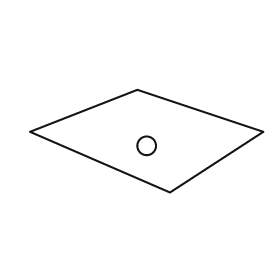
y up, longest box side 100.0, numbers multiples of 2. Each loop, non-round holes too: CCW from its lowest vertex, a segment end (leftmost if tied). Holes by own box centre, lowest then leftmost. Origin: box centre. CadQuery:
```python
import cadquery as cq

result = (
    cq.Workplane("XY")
    .moveTo(10.0, -22.0)
    .lineTo(50.0, 4.0)
    .lineTo(-4.0, 22.0)
    .lineTo(-50.0, 4.0)
    .close()
    .moveTo(0.0, -2.0)
    .circle(4.0)
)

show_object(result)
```